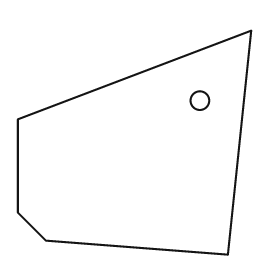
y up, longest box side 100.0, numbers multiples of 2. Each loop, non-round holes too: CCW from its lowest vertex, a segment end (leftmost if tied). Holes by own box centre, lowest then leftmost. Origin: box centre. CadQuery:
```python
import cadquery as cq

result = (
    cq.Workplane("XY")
    .moveTo(40.0, -48.0)
    .lineTo(50.0, 48.0)
    .lineTo(-50.0, 10.0)
    .lineTo(-50.0, -30.0)
    .lineTo(-38.0, -42.0)
    .close()
    .moveTo(28.0, 18.0)
    .circle(4.0)
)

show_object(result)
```